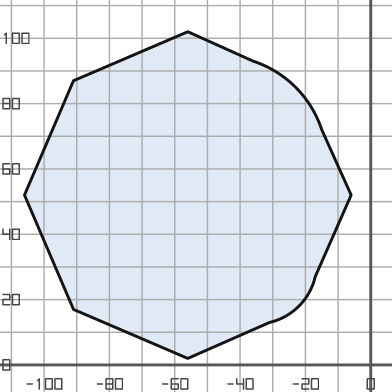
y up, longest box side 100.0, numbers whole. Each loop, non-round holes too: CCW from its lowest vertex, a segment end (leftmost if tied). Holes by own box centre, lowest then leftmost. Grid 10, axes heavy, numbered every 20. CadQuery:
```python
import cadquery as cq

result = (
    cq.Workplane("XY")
    .moveTo(-56.0, 2.0)
    .lineTo(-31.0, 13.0)
    .threePointArc((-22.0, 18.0), (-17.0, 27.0))
    .lineTo(-6.0, 52.0)
    .lineTo(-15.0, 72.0)
    .threePointArc((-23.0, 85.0), (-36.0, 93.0))
    .lineTo(-56.0, 102.0)
    .lineTo(-91.0, 87.0)
    .lineTo(-106.0, 52.0)
    .lineTo(-91.0, 17.0)
    .close()
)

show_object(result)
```